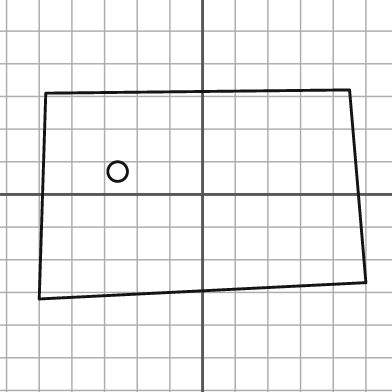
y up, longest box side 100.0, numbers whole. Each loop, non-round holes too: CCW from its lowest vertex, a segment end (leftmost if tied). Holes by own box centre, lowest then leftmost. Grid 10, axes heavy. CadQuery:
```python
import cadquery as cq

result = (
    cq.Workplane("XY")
    .moveTo(-50.0, -32.0)
    .lineTo(50.0, -27.0)
    .lineTo(45.0, 32.0)
    .lineTo(-48.0, 31.0)
    .close()
    .moveTo(-26.0, 7.0)
    .circle(3.0)
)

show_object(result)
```